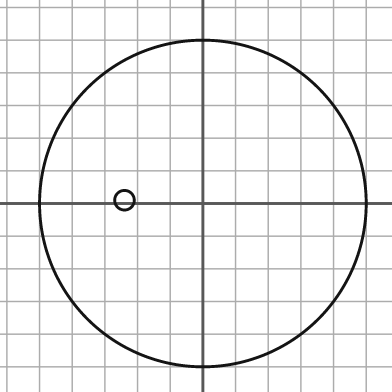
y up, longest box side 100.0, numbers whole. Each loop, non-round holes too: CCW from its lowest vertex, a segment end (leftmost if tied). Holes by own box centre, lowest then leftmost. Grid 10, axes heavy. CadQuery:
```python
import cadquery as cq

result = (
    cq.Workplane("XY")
    .moveTo(0.0, 0.0)
    .circle(50.0)
    .moveTo(-24.0, 1.0)
    .circle(3.0)
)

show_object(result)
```